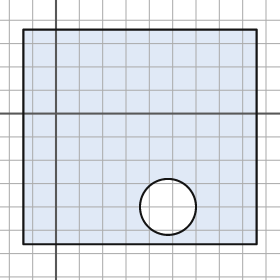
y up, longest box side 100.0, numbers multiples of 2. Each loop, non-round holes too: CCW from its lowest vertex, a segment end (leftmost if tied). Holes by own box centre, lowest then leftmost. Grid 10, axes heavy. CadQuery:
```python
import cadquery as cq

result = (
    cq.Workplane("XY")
    .moveTo(-14.0, -56.0)
    .lineTo(86.0, -56.0)
    .lineTo(86.0, 36.0)
    .lineTo(-14.0, 36.0)
    .close()
    .moveTo(48.0, -40.0)
    .circle(12.0)
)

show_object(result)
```